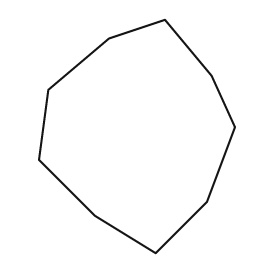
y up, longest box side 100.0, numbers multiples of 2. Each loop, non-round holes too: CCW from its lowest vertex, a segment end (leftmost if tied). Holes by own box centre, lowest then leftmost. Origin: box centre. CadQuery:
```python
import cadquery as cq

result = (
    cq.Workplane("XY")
    .moveTo(8.0, -50.0)
    .lineTo(30.0, -28.0)
    .lineTo(42.0, 4.0)
    .lineTo(32.0, 26.0)
    .lineTo(12.0, 50.0)
    .lineTo(-12.0, 42.0)
    .lineTo(-38.0, 20.0)
    .lineTo(-42.0, -10.0)
    .lineTo(-18.0, -34.0)
    .close()
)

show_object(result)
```